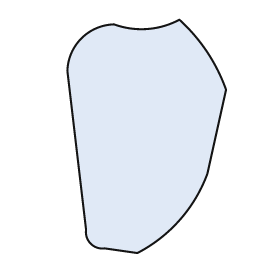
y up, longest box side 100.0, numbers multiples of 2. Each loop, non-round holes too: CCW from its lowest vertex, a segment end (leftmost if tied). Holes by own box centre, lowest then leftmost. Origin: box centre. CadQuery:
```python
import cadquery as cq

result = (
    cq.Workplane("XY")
    .moveTo(-4.0, -50.0)
    .threePointArc((14.0, -36.0), (26.0, -16.0))
    .lineTo(34.0, 20.0)
    .threePointArc((26.0, 36.0), (14.0, 50.0))
    .threePointArc((0.0, 46.0), (-14.0, 48.0))
    .threePointArc((-28.0, 42.0), (-34.0, 28.0))
    .lineTo(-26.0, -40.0)
    .threePointArc((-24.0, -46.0), (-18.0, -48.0))
    .close()
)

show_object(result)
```